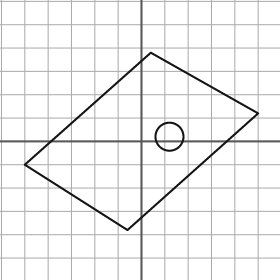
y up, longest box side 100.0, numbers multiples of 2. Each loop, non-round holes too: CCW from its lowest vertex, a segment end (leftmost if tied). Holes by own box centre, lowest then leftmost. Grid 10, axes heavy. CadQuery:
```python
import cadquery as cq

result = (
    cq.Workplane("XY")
    .moveTo(-6.0, -38.0)
    .lineTo(50.0, 12.0)
    .lineTo(4.0, 38.0)
    .lineTo(-50.0, -10.0)
    .close()
    .moveTo(12.0, 2.0)
    .circle(6.0)
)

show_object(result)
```